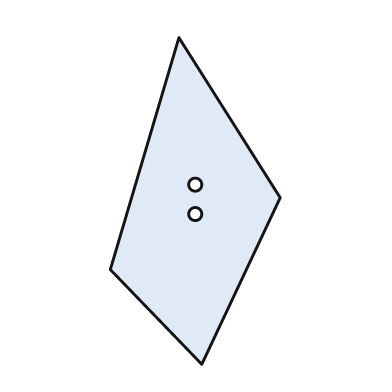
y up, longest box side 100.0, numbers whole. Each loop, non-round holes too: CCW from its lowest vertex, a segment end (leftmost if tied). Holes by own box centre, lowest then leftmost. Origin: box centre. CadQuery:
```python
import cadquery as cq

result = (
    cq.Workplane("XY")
    .moveTo(2.0, -50.0)
    .lineTo(26.0, 1.0)
    .lineTo(-5.0, 50.0)
    .lineTo(-26.0, -21.0)
    .close()
    .moveTo(0.0, -4.0)
    .circle(2.0)
    .moveTo(0.0, 5.0)
    .circle(2.0)
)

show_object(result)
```